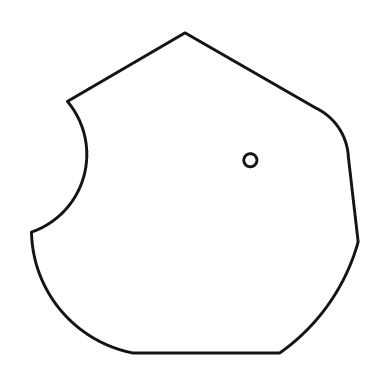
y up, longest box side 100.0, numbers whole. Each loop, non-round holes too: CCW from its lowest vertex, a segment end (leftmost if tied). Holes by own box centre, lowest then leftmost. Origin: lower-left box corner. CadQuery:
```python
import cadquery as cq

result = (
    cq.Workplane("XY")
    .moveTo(31.0, 0.0)
    .lineTo(76.0, 0.0)
    .threePointArc((91.0, 15.0), (100.0, 34.0))
    .lineTo(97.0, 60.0)
    .threePointArc((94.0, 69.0), (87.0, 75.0))
    .lineTo(47.0, 98.0)
    .lineTo(11.0, 77.0)
    .threePointArc((16.0, 54.0), (0.0, 37.0))
    .threePointArc((9.0, 13.0), (31.0, 0.0))
    .close()
    .moveTo(67.0, 59.0)
    .circle(2.0)
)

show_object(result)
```